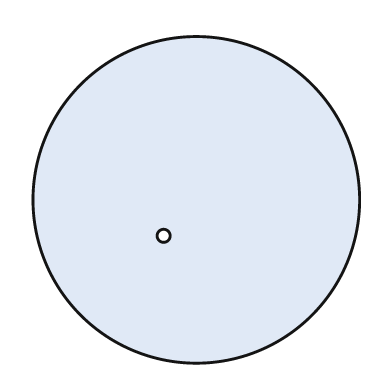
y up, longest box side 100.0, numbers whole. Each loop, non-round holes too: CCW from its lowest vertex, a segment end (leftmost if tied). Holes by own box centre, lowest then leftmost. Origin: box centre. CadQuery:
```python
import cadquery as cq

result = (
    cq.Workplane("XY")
    .moveTo(0.0, 0.0)
    .circle(50.0)
    .moveTo(-10.0, -11.0)
    .circle(2.0)
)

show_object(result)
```